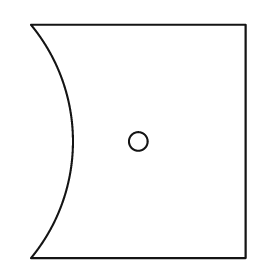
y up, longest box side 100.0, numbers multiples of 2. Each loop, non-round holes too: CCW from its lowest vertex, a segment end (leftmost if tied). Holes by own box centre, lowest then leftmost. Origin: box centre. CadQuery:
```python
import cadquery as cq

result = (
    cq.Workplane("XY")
    .moveTo(-46.0, -50.0)
    .lineTo(46.0, -50.0)
    .lineTo(46.0, 50.0)
    .lineTo(-46.0, 50.0)
    .threePointArc((-28.0, 0.0), (-46.0, -50.0))
    .close()
    .moveTo(0.0, 0.0)
    .circle(4.0)
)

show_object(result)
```